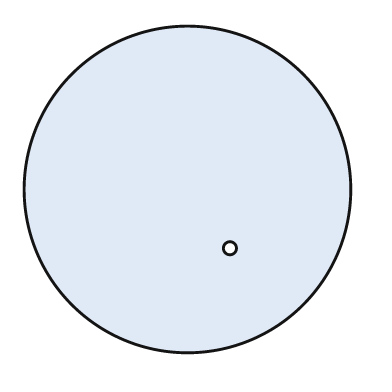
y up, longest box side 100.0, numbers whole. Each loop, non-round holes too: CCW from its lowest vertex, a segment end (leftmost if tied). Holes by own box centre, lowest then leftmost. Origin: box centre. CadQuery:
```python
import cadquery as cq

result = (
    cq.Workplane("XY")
    .moveTo(0.0, 0.0)
    .circle(50.0)
    .moveTo(13.0, -18.0)
    .circle(2.0)
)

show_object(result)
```